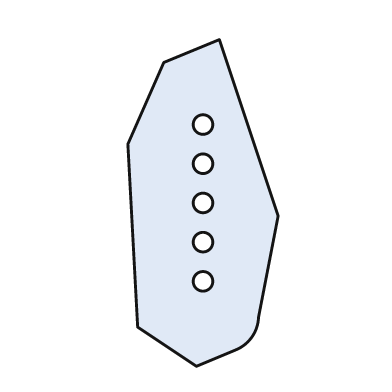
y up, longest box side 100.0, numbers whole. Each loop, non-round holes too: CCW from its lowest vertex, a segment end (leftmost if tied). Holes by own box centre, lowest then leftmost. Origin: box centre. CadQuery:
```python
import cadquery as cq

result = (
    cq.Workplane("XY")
    .moveTo(-2.0, -50.0)
    .lineTo(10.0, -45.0)
    .threePointArc((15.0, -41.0), (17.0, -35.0))
    .lineTo(23.0, -4.0)
    .lineTo(5.0, 50.0)
    .lineTo(-12.0, 43.0)
    .lineTo(-23.0, 18.0)
    .lineTo(-20.0, -38.0)
    .close()
    .moveTo(0.0, -24.0)
    .circle(3.0)
    .moveTo(0.0, -12.0)
    .circle(3.0)
    .moveTo(0.0, 0.0)
    .circle(3.0)
    .moveTo(0.0, 12.0)
    .circle(3.0)
    .moveTo(0.0, 24.0)
    .circle(3.0)
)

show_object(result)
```